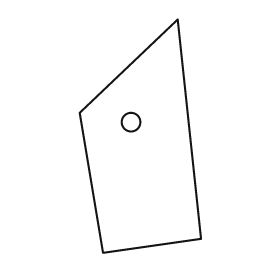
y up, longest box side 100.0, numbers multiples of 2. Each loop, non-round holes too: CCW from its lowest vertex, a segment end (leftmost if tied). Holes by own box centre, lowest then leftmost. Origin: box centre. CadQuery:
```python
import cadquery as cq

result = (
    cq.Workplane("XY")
    .moveTo(-16.0, -50.0)
    .lineTo(26.0, -44.0)
    .lineTo(16.0, 50.0)
    .lineTo(-26.0, 10.0)
    .close()
    .moveTo(-4.0, 6.0)
    .circle(4.0)
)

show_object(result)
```